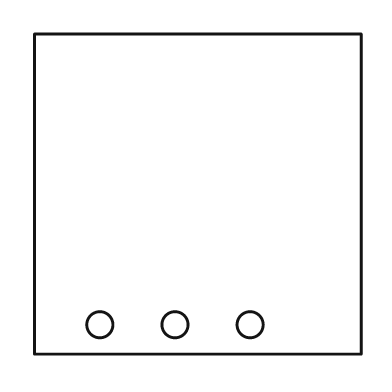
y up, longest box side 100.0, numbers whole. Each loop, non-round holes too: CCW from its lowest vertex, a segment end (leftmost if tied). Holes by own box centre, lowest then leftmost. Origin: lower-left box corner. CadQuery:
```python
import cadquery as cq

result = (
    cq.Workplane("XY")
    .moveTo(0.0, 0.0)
    .lineTo(100.0, 0.0)
    .lineTo(100.0, 98.0)
    .lineTo(0.0, 98.0)
    .close()
    .moveTo(20.0, 9.0)
    .circle(4.0)
    .moveTo(43.0, 9.0)
    .circle(4.0)
    .moveTo(66.0, 9.0)
    .circle(4.0)
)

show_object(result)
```